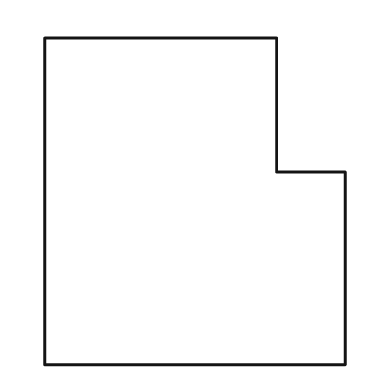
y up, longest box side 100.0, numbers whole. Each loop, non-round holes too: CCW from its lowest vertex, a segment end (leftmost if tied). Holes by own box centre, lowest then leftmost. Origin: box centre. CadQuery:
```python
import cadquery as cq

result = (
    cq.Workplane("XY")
    .moveTo(-46.0, -50.0)
    .lineTo(46.0, -50.0)
    .lineTo(46.0, 9.0)
    .lineTo(25.0, 9.0)
    .lineTo(25.0, 50.0)
    .lineTo(-46.0, 50.0)
    .close()
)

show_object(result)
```